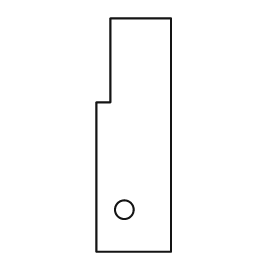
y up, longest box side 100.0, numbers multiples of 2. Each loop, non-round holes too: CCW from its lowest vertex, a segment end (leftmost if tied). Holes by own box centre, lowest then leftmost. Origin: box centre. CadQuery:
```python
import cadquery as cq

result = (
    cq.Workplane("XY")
    .moveTo(-16.0, -50.0)
    .lineTo(16.0, -50.0)
    .lineTo(16.0, 50.0)
    .lineTo(-10.0, 50.0)
    .lineTo(-10.0, 14.0)
    .lineTo(-16.0, 14.0)
    .close()
    .moveTo(-4.0, -32.0)
    .circle(4.0)
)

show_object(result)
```